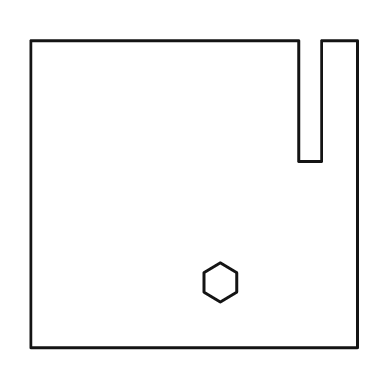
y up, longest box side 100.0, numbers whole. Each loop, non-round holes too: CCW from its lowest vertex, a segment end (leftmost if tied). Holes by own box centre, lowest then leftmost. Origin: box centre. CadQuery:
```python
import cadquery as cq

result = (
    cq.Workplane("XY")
    .moveTo(-50.0, -47.0)
    .lineTo(50.0, -47.0)
    .lineTo(50.0, 47.0)
    .lineTo(39.0, 47.0)
    .lineTo(39.0, 10.0)
    .lineTo(32.0, 10.0)
    .lineTo(32.0, 47.0)
    .lineTo(-50.0, 47.0)
    .close()
    .moveTo(8.0, -33.0)
    .lineTo(13.0, -30.0)
    .lineTo(13.0, -24.0)
    .lineTo(8.0, -21.0)
    .lineTo(3.0, -24.0)
    .lineTo(3.0, -30.0)
    .close()
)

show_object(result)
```